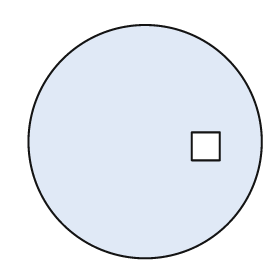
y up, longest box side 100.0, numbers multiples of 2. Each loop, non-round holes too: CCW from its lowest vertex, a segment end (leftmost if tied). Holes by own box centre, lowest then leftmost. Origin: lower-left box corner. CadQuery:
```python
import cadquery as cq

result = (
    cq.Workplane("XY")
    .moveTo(50.0, 50.0)
    .circle(50.0)
    .moveTo(70.0, 42.0)
    .lineTo(82.0, 42.0)
    .lineTo(82.0, 54.0)
    .lineTo(70.0, 54.0)
    .close()
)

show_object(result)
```